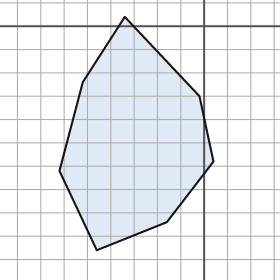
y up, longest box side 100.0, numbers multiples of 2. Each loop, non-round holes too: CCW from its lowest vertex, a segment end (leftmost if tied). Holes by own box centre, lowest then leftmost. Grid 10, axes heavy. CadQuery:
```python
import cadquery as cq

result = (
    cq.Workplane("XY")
    .moveTo(-46.0, -96.0)
    .lineTo(-16.0, -84.0)
    .lineTo(4.0, -58.0)
    .lineTo(-2.0, -30.0)
    .lineTo(-34.0, 4.0)
    .lineTo(-52.0, -24.0)
    .lineTo(-62.0, -62.0)
    .close()
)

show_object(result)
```